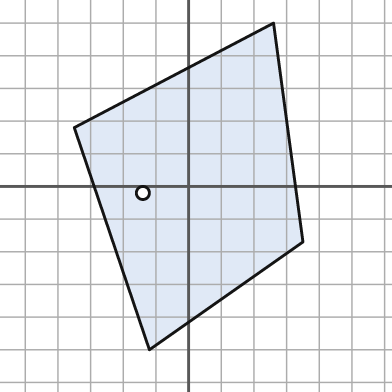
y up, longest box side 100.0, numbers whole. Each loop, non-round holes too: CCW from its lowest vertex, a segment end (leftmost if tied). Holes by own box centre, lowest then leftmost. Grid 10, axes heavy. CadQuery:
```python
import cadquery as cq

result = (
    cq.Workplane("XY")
    .moveTo(-12.0, -50.0)
    .lineTo(35.0, -17.0)
    .lineTo(26.0, 50.0)
    .lineTo(-35.0, 18.0)
    .close()
    .moveTo(-14.0, -2.0)
    .circle(2.0)
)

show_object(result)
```